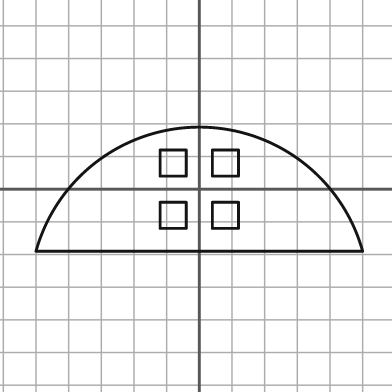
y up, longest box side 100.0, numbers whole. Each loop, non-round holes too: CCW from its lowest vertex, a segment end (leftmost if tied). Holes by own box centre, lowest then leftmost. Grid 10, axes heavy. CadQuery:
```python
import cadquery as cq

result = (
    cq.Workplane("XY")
    .moveTo(-50.0, -19.0)
    .lineTo(50.0, -19.0)
    .threePointArc((0.0, 19.0), (-50.0, -19.0))
    .close()
    .moveTo(-12.0, -12.0)
    .lineTo(-4.0, -12.0)
    .lineTo(-4.0, -4.0)
    .lineTo(-12.0, -4.0)
    .close()
    .moveTo(4.0, -12.0)
    .lineTo(12.0, -12.0)
    .lineTo(12.0, -4.0)
    .lineTo(4.0, -4.0)
    .close()
    .moveTo(-12.0, 4.0)
    .lineTo(-4.0, 4.0)
    .lineTo(-4.0, 12.0)
    .lineTo(-12.0, 12.0)
    .close()
    .moveTo(4.0, 4.0)
    .lineTo(12.0, 4.0)
    .lineTo(12.0, 12.0)
    .lineTo(4.0, 12.0)
    .close()
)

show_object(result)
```